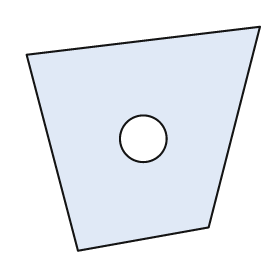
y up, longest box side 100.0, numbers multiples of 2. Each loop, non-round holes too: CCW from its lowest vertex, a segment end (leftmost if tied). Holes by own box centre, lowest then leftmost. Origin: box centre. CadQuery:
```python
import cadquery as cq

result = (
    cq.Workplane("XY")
    .moveTo(-28.0, -48.0)
    .lineTo(28.0, -38.0)
    .lineTo(50.0, 48.0)
    .lineTo(-50.0, 36.0)
    .close()
    .moveTo(0.0, 0.0)
    .circle(10.0)
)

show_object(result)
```